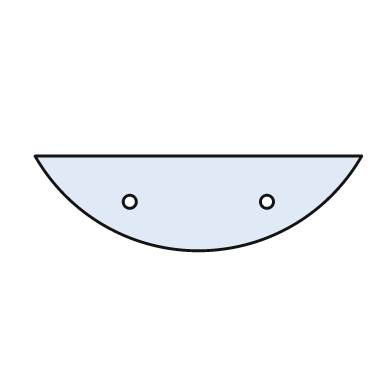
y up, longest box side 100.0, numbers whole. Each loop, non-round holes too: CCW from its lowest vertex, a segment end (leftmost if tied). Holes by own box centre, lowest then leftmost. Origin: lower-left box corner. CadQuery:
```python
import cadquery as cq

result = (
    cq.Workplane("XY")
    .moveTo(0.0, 29.0)
    .threePointArc((50.0, 0.0), (100.0, 29.0))
    .close()
    .moveTo(29.0, 15.0)
    .circle(2.0)
    .moveTo(71.0, 15.0)
    .circle(2.0)
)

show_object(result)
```